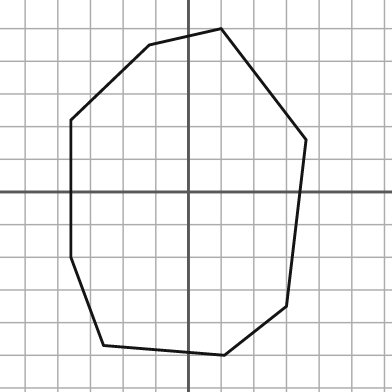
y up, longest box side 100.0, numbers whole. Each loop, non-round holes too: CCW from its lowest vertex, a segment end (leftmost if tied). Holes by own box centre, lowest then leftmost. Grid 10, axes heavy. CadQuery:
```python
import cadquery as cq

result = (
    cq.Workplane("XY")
    .moveTo(11.0, -50.0)
    .lineTo(30.0, -35.0)
    .lineTo(36.0, 16.0)
    .lineTo(10.0, 50.0)
    .lineTo(-12.0, 45.0)
    .lineTo(-36.0, 22.0)
    .lineTo(-36.0, -20.0)
    .lineTo(-26.0, -47.0)
    .close()
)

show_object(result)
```